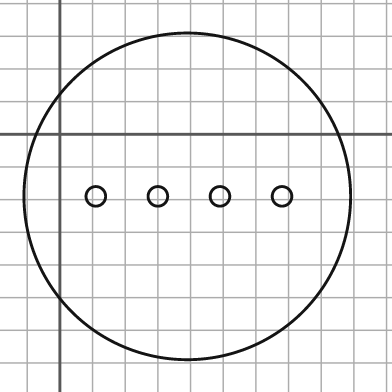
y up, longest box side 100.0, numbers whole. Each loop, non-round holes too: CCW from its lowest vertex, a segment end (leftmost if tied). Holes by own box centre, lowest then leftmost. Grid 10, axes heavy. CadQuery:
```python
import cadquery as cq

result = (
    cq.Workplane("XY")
    .moveTo(39.0, -19.0)
    .circle(50.0)
    .moveTo(11.0, -19.0)
    .circle(3.0)
    .moveTo(30.0, -19.0)
    .circle(3.0)
    .moveTo(49.0, -19.0)
    .circle(3.0)
    .moveTo(68.0, -19.0)
    .circle(3.0)
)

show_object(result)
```